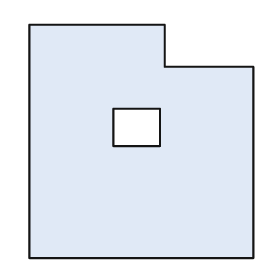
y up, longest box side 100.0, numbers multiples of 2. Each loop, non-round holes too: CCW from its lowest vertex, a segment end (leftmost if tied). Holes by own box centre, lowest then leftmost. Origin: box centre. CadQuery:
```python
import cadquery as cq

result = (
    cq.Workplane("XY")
    .moveTo(-48.0, -50.0)
    .lineTo(48.0, -50.0)
    .lineTo(48.0, 32.0)
    .lineTo(10.0, 32.0)
    .lineTo(10.0, 50.0)
    .lineTo(-48.0, 50.0)
    .close()
    .moveTo(-12.0, -2.0)
    .lineTo(8.0, -2.0)
    .lineTo(8.0, 14.0)
    .lineTo(-12.0, 14.0)
    .close()
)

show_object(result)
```